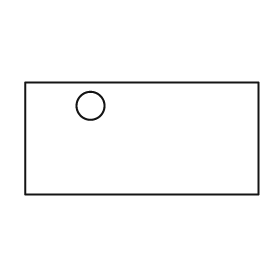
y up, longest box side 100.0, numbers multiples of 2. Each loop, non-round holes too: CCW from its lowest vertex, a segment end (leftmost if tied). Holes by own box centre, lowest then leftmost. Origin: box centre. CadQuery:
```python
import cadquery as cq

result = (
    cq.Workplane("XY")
    .moveTo(-50.0, -24.0)
    .lineTo(50.0, -24.0)
    .lineTo(50.0, 24.0)
    .lineTo(-50.0, 24.0)
    .close()
    .moveTo(-22.0, 14.0)
    .circle(6.0)
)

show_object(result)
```